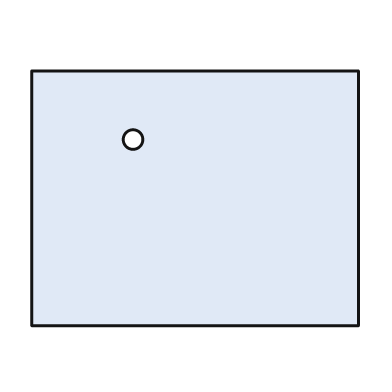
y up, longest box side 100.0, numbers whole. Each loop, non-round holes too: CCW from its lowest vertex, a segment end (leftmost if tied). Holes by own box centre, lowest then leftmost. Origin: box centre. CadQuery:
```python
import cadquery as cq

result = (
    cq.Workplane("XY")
    .moveTo(-50.0, -39.0)
    .lineTo(50.0, -39.0)
    .lineTo(50.0, 39.0)
    .lineTo(-50.0, 39.0)
    .close()
    .moveTo(-19.0, 18.0)
    .circle(3.0)
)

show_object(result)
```